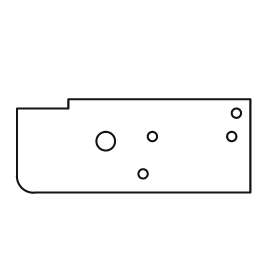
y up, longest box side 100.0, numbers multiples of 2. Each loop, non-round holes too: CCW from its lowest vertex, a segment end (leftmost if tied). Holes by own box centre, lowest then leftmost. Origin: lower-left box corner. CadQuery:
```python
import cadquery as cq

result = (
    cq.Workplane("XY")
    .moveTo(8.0, 0.0)
    .lineTo(100.0, 0.0)
    .lineTo(100.0, 40.0)
    .lineTo(22.0, 40.0)
    .lineTo(22.0, 36.0)
    .lineTo(0.0, 36.0)
    .lineTo(0.0, 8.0)
    .threePointArc((2.0, 2.0), (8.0, 0.0))
    .close()
    .moveTo(54.0, 8.0)
    .circle(2.0)
    .moveTo(38.0, 22.0)
    .circle(4.0)
    .moveTo(58.0, 24.0)
    .circle(2.0)
    .moveTo(92.0, 24.0)
    .circle(2.0)
    .moveTo(94.0, 34.0)
    .circle(2.0)
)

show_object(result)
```